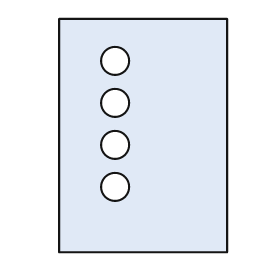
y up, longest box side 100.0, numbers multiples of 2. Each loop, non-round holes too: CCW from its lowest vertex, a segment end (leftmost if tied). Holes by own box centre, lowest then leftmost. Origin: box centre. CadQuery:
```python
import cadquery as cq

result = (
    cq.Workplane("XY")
    .moveTo(-36.0, -50.0)
    .lineTo(36.0, -50.0)
    .lineTo(36.0, 50.0)
    .lineTo(-36.0, 50.0)
    .close()
    .moveTo(-12.0, -22.0)
    .circle(6.0)
    .moveTo(-12.0, -4.0)
    .circle(6.0)
    .moveTo(-12.0, 14.0)
    .circle(6.0)
    .moveTo(-12.0, 32.0)
    .circle(6.0)
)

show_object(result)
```